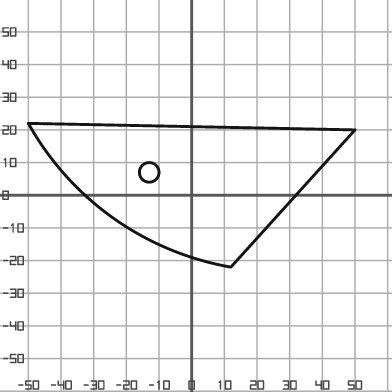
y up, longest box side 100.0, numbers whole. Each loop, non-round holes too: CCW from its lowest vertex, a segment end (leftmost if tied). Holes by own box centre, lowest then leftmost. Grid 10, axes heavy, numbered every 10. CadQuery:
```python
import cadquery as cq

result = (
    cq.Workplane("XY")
    .moveTo(12.0, -22.0)
    .lineTo(50.0, 20.0)
    .lineTo(-50.0, 22.0)
    .threePointArc((-24.0, -7.0), (12.0, -22.0))
    .close()
    .moveTo(-13.0, 7.0)
    .circle(3.0)
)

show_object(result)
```